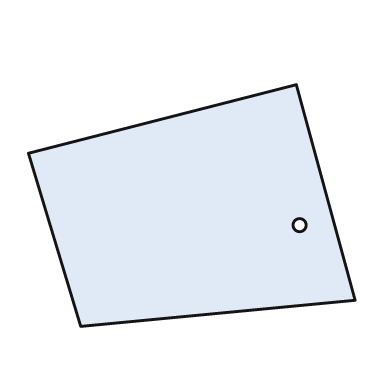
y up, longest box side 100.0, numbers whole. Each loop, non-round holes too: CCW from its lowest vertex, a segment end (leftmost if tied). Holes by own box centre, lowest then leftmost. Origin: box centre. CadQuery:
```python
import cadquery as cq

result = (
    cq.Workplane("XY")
    .moveTo(-34.0, -37.0)
    .lineTo(50.0, -29.0)
    .lineTo(32.0, 37.0)
    .lineTo(-50.0, 16.0)
    .close()
    .moveTo(33.0, -6.0)
    .circle(2.0)
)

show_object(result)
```